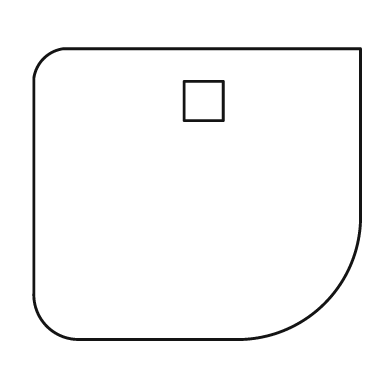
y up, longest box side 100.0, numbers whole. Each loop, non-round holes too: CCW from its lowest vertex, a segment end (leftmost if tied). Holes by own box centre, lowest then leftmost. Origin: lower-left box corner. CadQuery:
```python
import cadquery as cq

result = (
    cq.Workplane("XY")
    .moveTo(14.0, 0.0)
    .lineTo(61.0, 0.0)
    .threePointArc((89.0, 11.0), (100.0, 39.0))
    .lineTo(100.0, 89.0)
    .lineTo(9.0, 89.0)
    .threePointArc((3.0, 86.0), (0.0, 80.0))
    .lineTo(0.0, 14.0)
    .threePointArc((4.0, 4.0), (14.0, 0.0))
    .close()
    .moveTo(46.0, 67.0)
    .lineTo(58.0, 67.0)
    .lineTo(58.0, 79.0)
    .lineTo(46.0, 79.0)
    .close()
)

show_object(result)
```